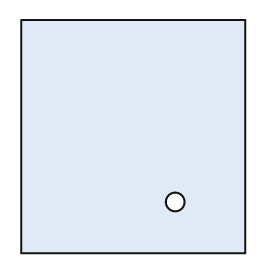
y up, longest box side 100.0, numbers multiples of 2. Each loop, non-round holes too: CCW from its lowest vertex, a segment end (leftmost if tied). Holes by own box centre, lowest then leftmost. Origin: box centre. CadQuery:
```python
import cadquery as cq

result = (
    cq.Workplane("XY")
    .moveTo(-48.0, -50.0)
    .lineTo(48.0, -50.0)
    .lineTo(48.0, 50.0)
    .lineTo(-48.0, 50.0)
    .close()
    .moveTo(18.0, -28.0)
    .circle(4.0)
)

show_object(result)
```